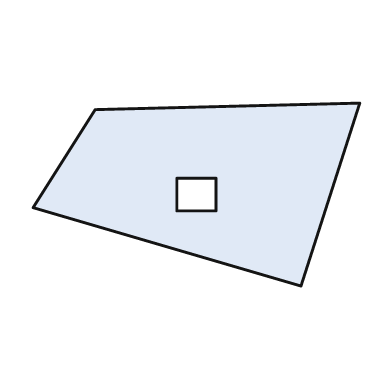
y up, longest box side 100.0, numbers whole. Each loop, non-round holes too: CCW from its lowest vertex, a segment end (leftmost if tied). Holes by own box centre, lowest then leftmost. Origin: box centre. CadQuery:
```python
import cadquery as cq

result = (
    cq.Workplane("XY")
    .moveTo(32.0, -28.0)
    .lineTo(50.0, 28.0)
    .lineTo(-31.0, 26.0)
    .lineTo(-50.0, -4.0)
    .close()
    .moveTo(-6.0, -5.0)
    .lineTo(6.0, -5.0)
    .lineTo(6.0, 5.0)
    .lineTo(-6.0, 5.0)
    .close()
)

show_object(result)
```